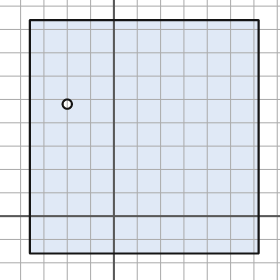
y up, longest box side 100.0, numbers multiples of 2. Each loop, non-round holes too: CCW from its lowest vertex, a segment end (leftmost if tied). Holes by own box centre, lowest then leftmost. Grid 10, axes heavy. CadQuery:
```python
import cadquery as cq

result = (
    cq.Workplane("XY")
    .moveTo(-36.0, -16.0)
    .lineTo(62.0, -16.0)
    .lineTo(62.0, 84.0)
    .lineTo(-36.0, 84.0)
    .close()
    .moveTo(-20.0, 48.0)
    .circle(2.0)
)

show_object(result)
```